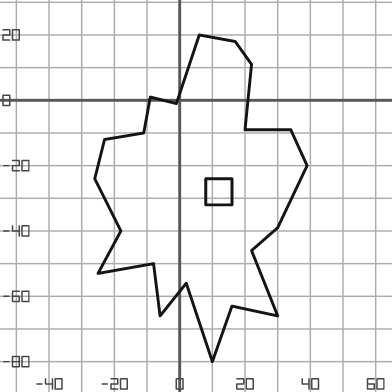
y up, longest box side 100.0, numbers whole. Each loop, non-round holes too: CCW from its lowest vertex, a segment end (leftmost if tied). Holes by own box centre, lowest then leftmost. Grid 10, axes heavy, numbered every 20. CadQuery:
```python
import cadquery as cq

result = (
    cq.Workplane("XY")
    .moveTo(10.0, -80.0)
    .lineTo(16.0, -63.0)
    .lineTo(30.0, -66.0)
    .lineTo(22.0, -46.0)
    .lineTo(30.0, -39.0)
    .lineTo(39.0, -20.0)
    .lineTo(34.0, -9.0)
    .lineTo(20.0, -9.0)
    .lineTo(22.0, 11.0)
    .lineTo(17.0, 18.0)
    .lineTo(6.0, 20.0)
    .lineTo(-1.0, -1.0)
    .lineTo(-9.0, 1.0)
    .lineTo(-11.0, -10.0)
    .lineTo(-23.0, -12.0)
    .lineTo(-26.0, -24.0)
    .lineTo(-18.0, -40.0)
    .lineTo(-25.0, -53.0)
    .lineTo(-8.0, -50.0)
    .lineTo(-6.0, -66.0)
    .lineTo(2.0, -56.0)
    .close()
    .moveTo(8.0, -32.0)
    .lineTo(16.0, -32.0)
    .lineTo(16.0, -24.0)
    .lineTo(8.0, -24.0)
    .close()
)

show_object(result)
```